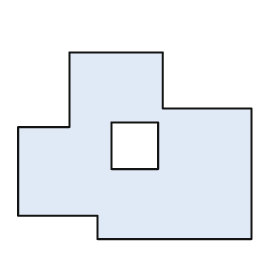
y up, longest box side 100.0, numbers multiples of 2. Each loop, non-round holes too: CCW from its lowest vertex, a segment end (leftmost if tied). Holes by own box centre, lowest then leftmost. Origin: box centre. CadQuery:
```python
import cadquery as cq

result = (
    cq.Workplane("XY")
    .moveTo(-16.0, -40.0)
    .lineTo(50.0, -40.0)
    .lineTo(50.0, 16.0)
    .lineTo(12.0, 16.0)
    .lineTo(12.0, 40.0)
    .lineTo(-28.0, 40.0)
    .lineTo(-28.0, 8.0)
    .lineTo(-50.0, 8.0)
    .lineTo(-50.0, -30.0)
    .lineTo(-16.0, -30.0)
    .close()
    .moveTo(-10.0, -10.0)
    .lineTo(10.0, -10.0)
    .lineTo(10.0, 10.0)
    .lineTo(-10.0, 10.0)
    .close()
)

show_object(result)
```